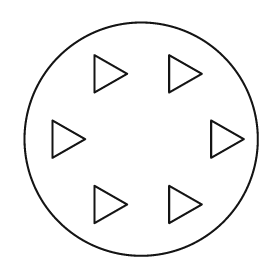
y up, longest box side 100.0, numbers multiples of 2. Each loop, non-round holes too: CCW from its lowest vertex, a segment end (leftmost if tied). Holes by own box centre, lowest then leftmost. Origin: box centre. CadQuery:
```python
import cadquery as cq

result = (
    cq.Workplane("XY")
    .moveTo(0.0, 0.0)
    .circle(50.0)
    .moveTo(-20.0, -36.0)
    .lineTo(-6.0, -28.0)
    .lineTo(-20.0, -20.0)
    .close()
    .moveTo(12.0, -36.0)
    .lineTo(26.0, -28.0)
    .lineTo(12.0, -20.0)
    .close()
    .moveTo(-38.0, -8.0)
    .lineTo(-24.0, 0.0)
    .lineTo(-38.0, 8.0)
    .close()
    .moveTo(30.0, -8.0)
    .lineTo(44.0, 0.0)
    .lineTo(30.0, 8.0)
    .close()
    .moveTo(-20.0, 20.0)
    .lineTo(-6.0, 28.0)
    .lineTo(-20.0, 36.0)
    .close()
    .moveTo(12.0, 20.0)
    .lineTo(26.0, 28.0)
    .lineTo(12.0, 36.0)
    .close()
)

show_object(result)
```